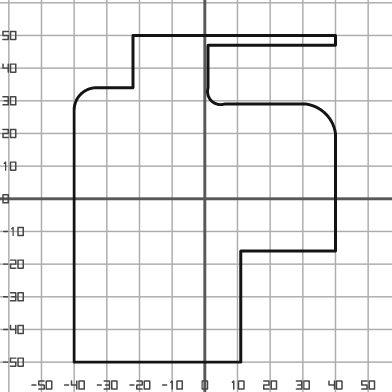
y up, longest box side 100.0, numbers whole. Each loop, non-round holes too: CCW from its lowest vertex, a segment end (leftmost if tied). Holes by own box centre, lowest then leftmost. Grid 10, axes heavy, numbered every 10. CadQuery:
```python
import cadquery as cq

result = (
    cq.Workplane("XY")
    .moveTo(-40.0, -50.0)
    .lineTo(11.0, -50.0)
    .lineTo(11.0, -16.0)
    .lineTo(40.0, -16.0)
    .lineTo(40.0, 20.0)
    .threePointArc((37.0, 26.0), (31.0, 29.0))
    .lineTo(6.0, 29.0)
    .threePointArc((2.0, 30.0), (1.0, 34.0))
    .lineTo(1.0, 47.0)
    .lineTo(40.0, 47.0)
    .lineTo(40.0, 50.0)
    .lineTo(-22.0, 50.0)
    .lineTo(-22.0, 34.0)
    .lineTo(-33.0, 34.0)
    .threePointArc((-38.0, 32.0), (-40.0, 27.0))
    .close()
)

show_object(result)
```